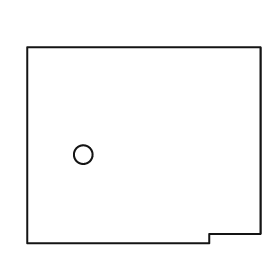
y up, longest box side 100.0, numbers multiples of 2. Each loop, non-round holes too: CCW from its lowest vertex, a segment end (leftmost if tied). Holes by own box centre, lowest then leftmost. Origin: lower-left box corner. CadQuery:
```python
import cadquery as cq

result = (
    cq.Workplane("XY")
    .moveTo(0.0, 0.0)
    .lineTo(78.0, 0.0)
    .lineTo(78.0, 4.0)
    .lineTo(100.0, 4.0)
    .lineTo(100.0, 84.0)
    .lineTo(0.0, 84.0)
    .close()
    .moveTo(24.0, 38.0)
    .circle(4.0)
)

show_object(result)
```